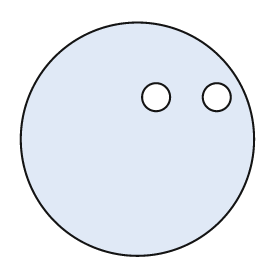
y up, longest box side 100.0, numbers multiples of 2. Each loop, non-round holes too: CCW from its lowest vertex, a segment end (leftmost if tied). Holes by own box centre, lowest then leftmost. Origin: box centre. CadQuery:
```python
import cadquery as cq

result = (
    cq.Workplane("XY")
    .moveTo(0.0, 0.0)
    .circle(50.0)
    .moveTo(8.0, 18.0)
    .circle(6.0)
    .moveTo(34.0, 18.0)
    .circle(6.0)
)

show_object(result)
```